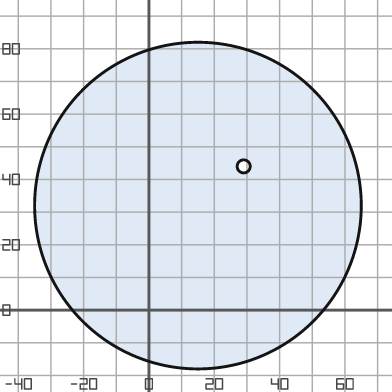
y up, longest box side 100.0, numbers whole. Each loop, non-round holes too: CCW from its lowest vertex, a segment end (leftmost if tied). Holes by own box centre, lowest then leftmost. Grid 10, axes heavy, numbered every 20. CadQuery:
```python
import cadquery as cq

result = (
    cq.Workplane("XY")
    .moveTo(15.0, 32.0)
    .circle(50.0)
    .moveTo(29.0, 44.0)
    .circle(2.0)
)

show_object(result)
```